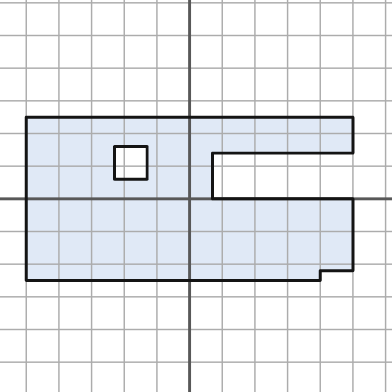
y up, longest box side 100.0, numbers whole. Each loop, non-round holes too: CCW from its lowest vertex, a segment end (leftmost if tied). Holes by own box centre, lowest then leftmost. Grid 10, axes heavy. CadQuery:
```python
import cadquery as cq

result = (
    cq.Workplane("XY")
    .moveTo(-50.0, -25.0)
    .lineTo(40.0, -25.0)
    .lineTo(40.0, -22.0)
    .lineTo(50.0, -22.0)
    .lineTo(50.0, 0.0)
    .lineTo(7.0, 0.0)
    .lineTo(7.0, 14.0)
    .lineTo(50.0, 14.0)
    .lineTo(50.0, 25.0)
    .lineTo(-50.0, 25.0)
    .close()
    .moveTo(-23.0, 6.0)
    .lineTo(-13.0, 6.0)
    .lineTo(-13.0, 16.0)
    .lineTo(-23.0, 16.0)
    .close()
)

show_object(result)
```